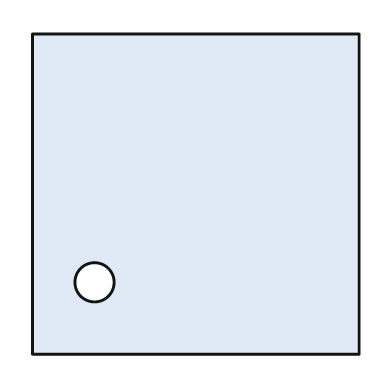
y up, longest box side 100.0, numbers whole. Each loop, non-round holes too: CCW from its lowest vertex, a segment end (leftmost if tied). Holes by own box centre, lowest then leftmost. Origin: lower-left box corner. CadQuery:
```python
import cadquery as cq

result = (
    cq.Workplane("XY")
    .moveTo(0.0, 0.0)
    .lineTo(100.0, 0.0)
    .lineTo(100.0, 98.0)
    .lineTo(0.0, 98.0)
    .close()
    .moveTo(19.0, 22.0)
    .circle(6.0)
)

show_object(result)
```